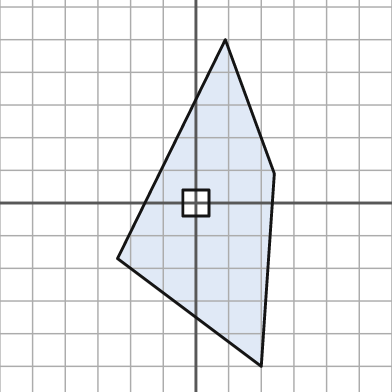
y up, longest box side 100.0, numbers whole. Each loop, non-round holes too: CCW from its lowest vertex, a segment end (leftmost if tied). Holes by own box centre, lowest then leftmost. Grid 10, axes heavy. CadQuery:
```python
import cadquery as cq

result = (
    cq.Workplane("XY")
    .moveTo(20.0, -50.0)
    .lineTo(24.0, 9.0)
    .lineTo(9.0, 50.0)
    .lineTo(-24.0, -17.0)
    .close()
    .moveTo(-4.0, -4.0)
    .lineTo(4.0, -4.0)
    .lineTo(4.0, 4.0)
    .lineTo(-4.0, 4.0)
    .close()
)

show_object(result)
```